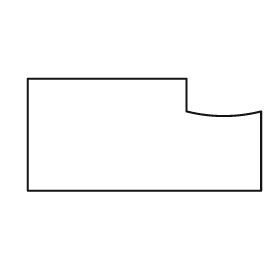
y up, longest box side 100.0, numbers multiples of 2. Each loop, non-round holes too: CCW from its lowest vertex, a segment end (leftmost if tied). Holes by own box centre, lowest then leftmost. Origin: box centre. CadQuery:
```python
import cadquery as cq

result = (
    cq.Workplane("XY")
    .moveTo(-50.0, -24.0)
    .lineTo(50.0, -24.0)
    .lineTo(50.0, 10.0)
    .threePointArc((34.0, 8.0), (18.0, 10.0))
    .lineTo(18.0, 24.0)
    .lineTo(-50.0, 24.0)
    .close()
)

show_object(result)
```